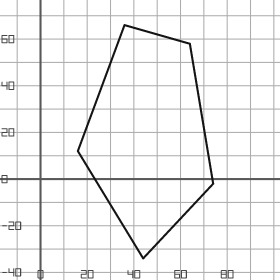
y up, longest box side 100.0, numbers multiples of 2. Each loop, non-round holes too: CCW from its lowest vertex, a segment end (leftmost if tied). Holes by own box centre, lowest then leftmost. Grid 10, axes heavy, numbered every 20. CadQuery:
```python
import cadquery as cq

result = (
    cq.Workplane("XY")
    .moveTo(44.0, -34.0)
    .lineTo(74.0, -2.0)
    .lineTo(64.0, 58.0)
    .lineTo(36.0, 66.0)
    .lineTo(16.0, 12.0)
    .close()
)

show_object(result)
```